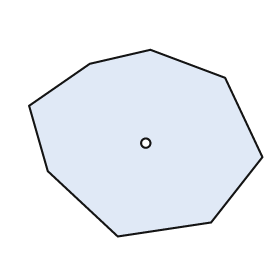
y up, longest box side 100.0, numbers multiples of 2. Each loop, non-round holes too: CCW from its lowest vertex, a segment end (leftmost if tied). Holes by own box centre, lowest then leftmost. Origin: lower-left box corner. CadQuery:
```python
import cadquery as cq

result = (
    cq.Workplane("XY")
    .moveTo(38.0, 0.0)
    .lineTo(78.0, 6.0)
    .lineTo(100.0, 34.0)
    .lineTo(84.0, 68.0)
    .lineTo(52.0, 80.0)
    .lineTo(26.0, 74.0)
    .lineTo(0.0, 56.0)
    .lineTo(8.0, 28.0)
    .close()
    .moveTo(50.0, 40.0)
    .circle(2.0)
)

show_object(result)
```